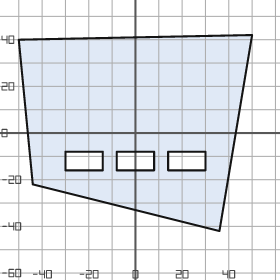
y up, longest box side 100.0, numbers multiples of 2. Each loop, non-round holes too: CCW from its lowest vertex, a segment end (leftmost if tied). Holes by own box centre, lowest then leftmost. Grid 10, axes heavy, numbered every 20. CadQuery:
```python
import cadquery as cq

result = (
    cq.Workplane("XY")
    .moveTo(36.0, -42.0)
    .lineTo(50.0, 42.0)
    .lineTo(-50.0, 40.0)
    .lineTo(-44.0, -22.0)
    .close()
    .moveTo(-30.0, -16.0)
    .lineTo(-14.0, -16.0)
    .lineTo(-14.0, -8.0)
    .lineTo(-30.0, -8.0)
    .close()
    .moveTo(-8.0, -16.0)
    .lineTo(8.0, -16.0)
    .lineTo(8.0, -8.0)
    .lineTo(-8.0, -8.0)
    .close()
    .moveTo(14.0, -16.0)
    .lineTo(30.0, -16.0)
    .lineTo(30.0, -8.0)
    .lineTo(14.0, -8.0)
    .close()
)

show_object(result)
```